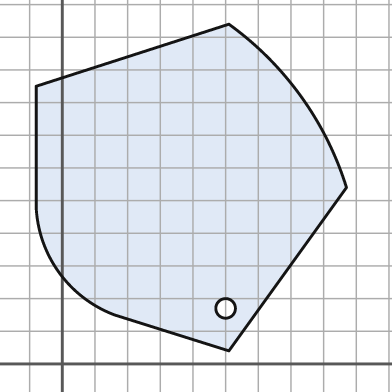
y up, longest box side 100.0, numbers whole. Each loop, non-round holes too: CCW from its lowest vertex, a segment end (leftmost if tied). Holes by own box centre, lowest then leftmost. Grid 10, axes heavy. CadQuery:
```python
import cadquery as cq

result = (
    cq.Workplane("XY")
    .moveTo(51.0, 4.0)
    .lineTo(87.0, 54.0)
    .threePointArc((73.0, 82.0), (51.0, 104.0))
    .lineTo(-8.0, 85.0)
    .lineTo(-8.0, 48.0)
    .threePointArc((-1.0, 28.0), (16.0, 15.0))
    .close()
    .moveTo(50.0, 17.0)
    .circle(3.0)
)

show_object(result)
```